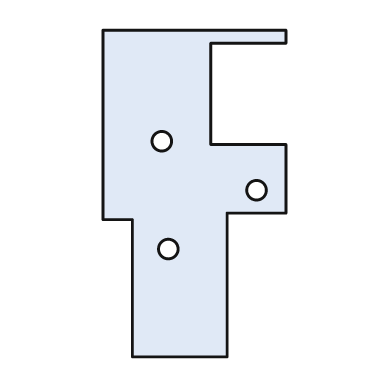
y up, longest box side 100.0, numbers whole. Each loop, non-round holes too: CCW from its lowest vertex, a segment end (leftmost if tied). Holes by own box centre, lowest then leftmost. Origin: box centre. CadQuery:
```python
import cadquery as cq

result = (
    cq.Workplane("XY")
    .moveTo(-19.0, -50.0)
    .lineTo(10.0, -50.0)
    .lineTo(10.0, -6.0)
    .lineTo(28.0, -6.0)
    .lineTo(28.0, 15.0)
    .lineTo(5.0, 15.0)
    .lineTo(5.0, 46.0)
    .lineTo(28.0, 46.0)
    .lineTo(28.0, 50.0)
    .lineTo(-28.0, 50.0)
    .lineTo(-28.0, -8.0)
    .lineTo(-19.0, -8.0)
    .close()
    .moveTo(-8.0, -17.0)
    .circle(3.0)
    .moveTo(19.0, 1.0)
    .circle(3.0)
    .moveTo(-10.0, 16.0)
    .circle(3.0)
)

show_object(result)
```